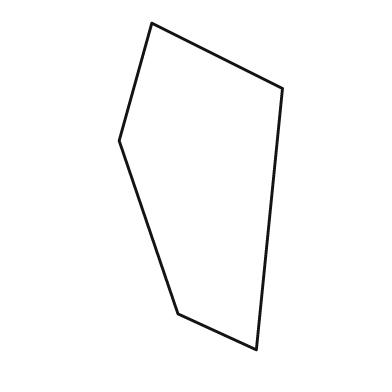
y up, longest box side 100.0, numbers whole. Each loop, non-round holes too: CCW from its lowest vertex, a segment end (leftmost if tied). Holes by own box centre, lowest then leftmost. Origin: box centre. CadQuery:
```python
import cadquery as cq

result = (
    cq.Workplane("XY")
    .moveTo(17.0, -50.0)
    .lineTo(25.0, 30.0)
    .lineTo(-15.0, 50.0)
    .lineTo(-25.0, 14.0)
    .lineTo(-7.0, -39.0)
    .close()
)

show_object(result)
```